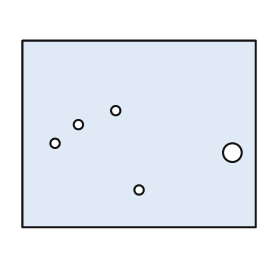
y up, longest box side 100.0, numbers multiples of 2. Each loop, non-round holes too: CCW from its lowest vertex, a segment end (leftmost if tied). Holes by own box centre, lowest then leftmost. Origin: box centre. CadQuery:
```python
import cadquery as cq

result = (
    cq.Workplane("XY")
    .moveTo(-50.0, -40.0)
    .lineTo(50.0, -40.0)
    .lineTo(50.0, 40.0)
    .lineTo(-50.0, 40.0)
    .close()
    .moveTo(0.0, -24.0)
    .circle(2.0)
    .moveTo(40.0, -8.0)
    .circle(4.0)
    .moveTo(-36.0, -4.0)
    .circle(2.0)
    .moveTo(-26.0, 4.0)
    .circle(2.0)
    .moveTo(-10.0, 10.0)
    .circle(2.0)
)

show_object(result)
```